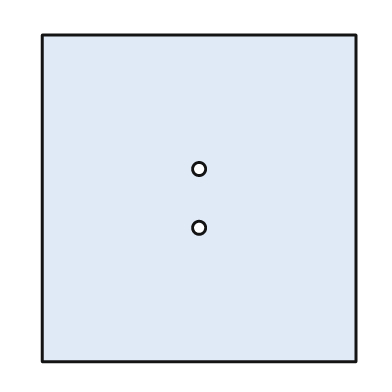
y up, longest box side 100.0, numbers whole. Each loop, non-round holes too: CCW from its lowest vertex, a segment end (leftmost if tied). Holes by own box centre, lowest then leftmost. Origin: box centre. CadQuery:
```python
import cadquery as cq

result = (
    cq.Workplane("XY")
    .moveTo(-48.0, -50.0)
    .lineTo(48.0, -50.0)
    .lineTo(48.0, 50.0)
    .lineTo(-48.0, 50.0)
    .close()
    .moveTo(0.0, -9.0)
    .circle(2.0)
    .moveTo(0.0, 9.0)
    .circle(2.0)
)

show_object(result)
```